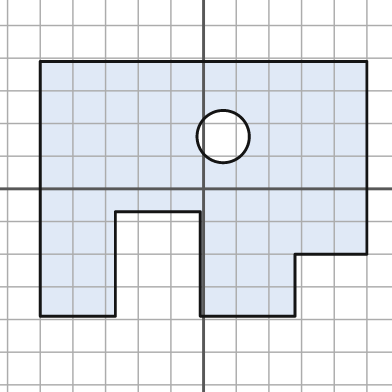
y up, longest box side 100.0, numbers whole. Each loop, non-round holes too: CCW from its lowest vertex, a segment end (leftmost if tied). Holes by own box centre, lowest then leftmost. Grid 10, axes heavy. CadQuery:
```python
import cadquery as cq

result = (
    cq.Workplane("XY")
    .moveTo(-50.0, -39.0)
    .lineTo(-27.0, -39.0)
    .lineTo(-27.0, -7.0)
    .lineTo(-1.0, -7.0)
    .lineTo(-1.0, -39.0)
    .lineTo(28.0, -39.0)
    .lineTo(28.0, -20.0)
    .lineTo(50.0, -20.0)
    .lineTo(50.0, 39.0)
    .lineTo(-50.0, 39.0)
    .close()
    .moveTo(6.0, 16.0)
    .circle(8.0)
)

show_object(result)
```